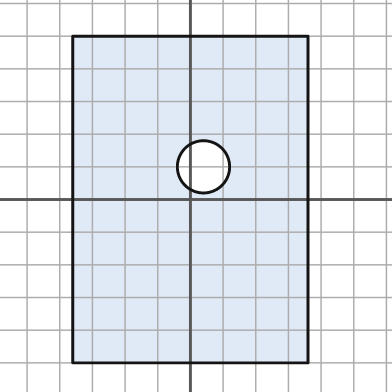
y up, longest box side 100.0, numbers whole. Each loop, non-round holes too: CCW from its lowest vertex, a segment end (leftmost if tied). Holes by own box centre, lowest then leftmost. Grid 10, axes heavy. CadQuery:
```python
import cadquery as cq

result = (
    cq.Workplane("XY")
    .moveTo(-36.0, -50.0)
    .lineTo(36.0, -50.0)
    .lineTo(36.0, 50.0)
    .lineTo(-36.0, 50.0)
    .close()
    .moveTo(4.0, 10.0)
    .circle(8.0)
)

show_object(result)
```